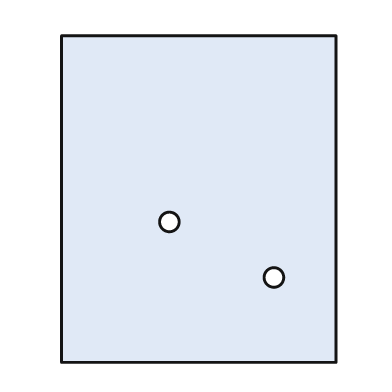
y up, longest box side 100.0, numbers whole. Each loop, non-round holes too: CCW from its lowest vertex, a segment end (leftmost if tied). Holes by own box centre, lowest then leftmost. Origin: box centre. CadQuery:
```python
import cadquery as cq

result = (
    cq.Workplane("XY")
    .moveTo(-42.0, -50.0)
    .lineTo(42.0, -50.0)
    .lineTo(42.0, 50.0)
    .lineTo(-42.0, 50.0)
    .close()
    .moveTo(23.0, -24.0)
    .circle(3.0)
    .moveTo(-9.0, -7.0)
    .circle(3.0)
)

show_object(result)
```